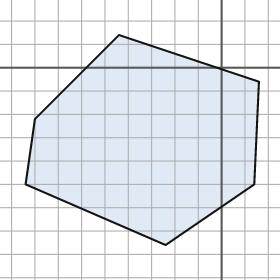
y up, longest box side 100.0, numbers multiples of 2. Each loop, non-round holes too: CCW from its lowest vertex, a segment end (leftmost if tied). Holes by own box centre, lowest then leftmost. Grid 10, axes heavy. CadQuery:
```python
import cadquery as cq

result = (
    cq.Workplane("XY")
    .moveTo(-24.0, -76.0)
    .lineTo(14.0, -50.0)
    .lineTo(16.0, -6.0)
    .lineTo(-44.0, 14.0)
    .lineTo(-80.0, -22.0)
    .lineTo(-84.0, -50.0)
    .close()
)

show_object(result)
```